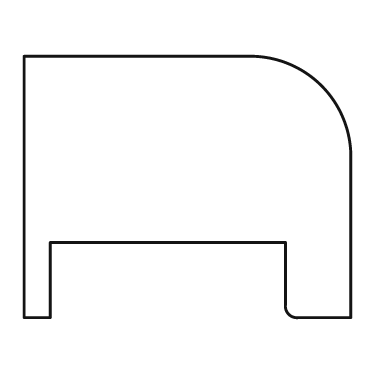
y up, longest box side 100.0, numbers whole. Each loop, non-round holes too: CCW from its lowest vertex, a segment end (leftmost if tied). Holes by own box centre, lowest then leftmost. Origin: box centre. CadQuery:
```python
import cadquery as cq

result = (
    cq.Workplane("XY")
    .moveTo(-50.0, -40.0)
    .lineTo(-42.0, -40.0)
    .lineTo(-42.0, -17.0)
    .lineTo(30.0, -17.0)
    .lineTo(30.0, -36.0)
    .threePointArc((31.0, -39.0), (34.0, -40.0))
    .lineTo(50.0, -40.0)
    .lineTo(50.0, 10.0)
    .threePointArc((41.0, 31.0), (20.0, 40.0))
    .lineTo(-50.0, 40.0)
    .close()
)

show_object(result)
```